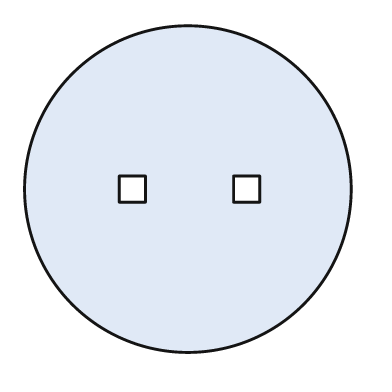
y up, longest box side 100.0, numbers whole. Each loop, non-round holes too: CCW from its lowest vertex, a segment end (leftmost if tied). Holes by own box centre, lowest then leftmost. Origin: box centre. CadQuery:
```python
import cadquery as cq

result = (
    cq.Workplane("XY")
    .moveTo(0.0, 0.0)
    .circle(50.0)
    .moveTo(-21.0, -4.0)
    .lineTo(-13.0, -4.0)
    .lineTo(-13.0, 4.0)
    .lineTo(-21.0, 4.0)
    .close()
    .moveTo(14.0, -4.0)
    .lineTo(22.0, -4.0)
    .lineTo(22.0, 4.0)
    .lineTo(14.0, 4.0)
    .close()
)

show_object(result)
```